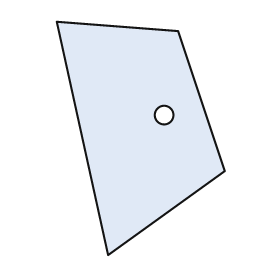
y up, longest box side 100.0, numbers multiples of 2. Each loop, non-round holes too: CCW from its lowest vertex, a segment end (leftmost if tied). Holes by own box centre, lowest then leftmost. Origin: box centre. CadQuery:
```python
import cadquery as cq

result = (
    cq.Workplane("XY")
    .moveTo(-14.0, -50.0)
    .lineTo(36.0, -14.0)
    .lineTo(16.0, 46.0)
    .lineTo(-36.0, 50.0)
    .close()
    .moveTo(10.0, 10.0)
    .circle(4.0)
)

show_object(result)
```